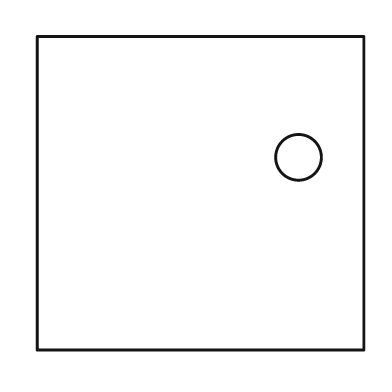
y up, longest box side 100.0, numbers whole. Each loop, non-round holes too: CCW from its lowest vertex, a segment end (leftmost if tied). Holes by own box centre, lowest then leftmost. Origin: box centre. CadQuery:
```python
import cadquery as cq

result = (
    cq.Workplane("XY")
    .moveTo(-50.0, -48.0)
    .lineTo(50.0, -48.0)
    .lineTo(50.0, 48.0)
    .lineTo(-50.0, 48.0)
    .close()
    .moveTo(30.0, 11.0)
    .circle(7.0)
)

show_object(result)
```